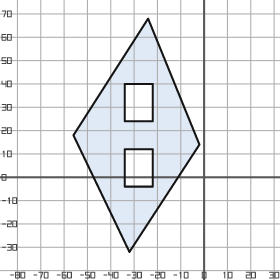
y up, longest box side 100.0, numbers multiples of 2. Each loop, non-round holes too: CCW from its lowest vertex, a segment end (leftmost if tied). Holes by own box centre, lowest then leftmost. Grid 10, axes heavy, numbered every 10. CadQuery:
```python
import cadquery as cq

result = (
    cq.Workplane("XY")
    .moveTo(-32.0, -32.0)
    .lineTo(-2.0, 14.0)
    .lineTo(-24.0, 68.0)
    .lineTo(-56.0, 18.0)
    .close()
    .moveTo(-34.0, -4.0)
    .lineTo(-22.0, -4.0)
    .lineTo(-22.0, 12.0)
    .lineTo(-34.0, 12.0)
    .close()
    .moveTo(-34.0, 24.0)
    .lineTo(-22.0, 24.0)
    .lineTo(-22.0, 40.0)
    .lineTo(-34.0, 40.0)
    .close()
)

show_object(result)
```